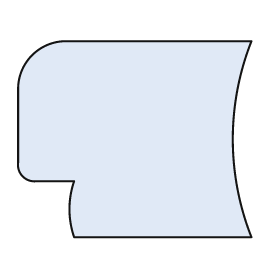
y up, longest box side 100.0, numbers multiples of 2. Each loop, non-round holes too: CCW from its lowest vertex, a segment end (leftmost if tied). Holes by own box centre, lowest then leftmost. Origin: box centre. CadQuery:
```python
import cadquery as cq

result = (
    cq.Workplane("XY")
    .moveTo(-26.0, -42.0)
    .lineTo(50.0, -42.0)
    .threePointArc((42.0, 0.0), (50.0, 42.0))
    .lineTo(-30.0, 42.0)
    .threePointArc((-44.0, 36.0), (-50.0, 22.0))
    .lineTo(-50.0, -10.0)
    .threePointArc((-48.0, -16.0), (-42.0, -18.0))
    .lineTo(-26.0, -18.0)
    .threePointArc((-28.0, -30.0), (-26.0, -42.0))
    .close()
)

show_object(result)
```